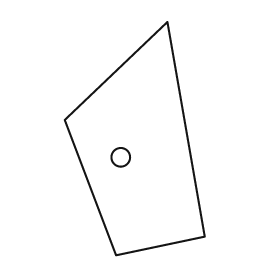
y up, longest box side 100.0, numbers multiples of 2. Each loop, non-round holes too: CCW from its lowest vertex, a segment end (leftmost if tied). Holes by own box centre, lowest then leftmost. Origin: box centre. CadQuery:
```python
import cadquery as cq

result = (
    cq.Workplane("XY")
    .moveTo(-8.0, -50.0)
    .lineTo(30.0, -42.0)
    .lineTo(14.0, 50.0)
    .lineTo(-30.0, 8.0)
    .close()
    .moveTo(-6.0, -8.0)
    .circle(4.0)
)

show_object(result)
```